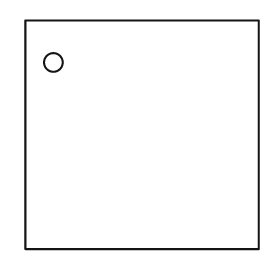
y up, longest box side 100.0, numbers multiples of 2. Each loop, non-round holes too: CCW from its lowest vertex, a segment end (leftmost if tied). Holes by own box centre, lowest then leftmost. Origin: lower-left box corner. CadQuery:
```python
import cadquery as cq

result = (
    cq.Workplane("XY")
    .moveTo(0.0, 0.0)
    .lineTo(100.0, 0.0)
    .lineTo(100.0, 98.0)
    .lineTo(0.0, 98.0)
    .close()
    .moveTo(12.0, 80.0)
    .circle(4.0)
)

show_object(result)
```